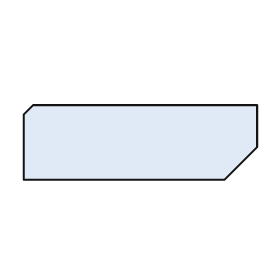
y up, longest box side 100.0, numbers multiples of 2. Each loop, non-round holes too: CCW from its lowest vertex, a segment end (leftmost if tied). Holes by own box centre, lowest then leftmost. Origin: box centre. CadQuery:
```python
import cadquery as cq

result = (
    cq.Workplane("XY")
    .moveTo(-50.0, -16.0)
    .lineTo(36.0, -16.0)
    .lineTo(50.0, -2.0)
    .lineTo(50.0, 16.0)
    .lineTo(-46.0, 16.0)
    .lineTo(-50.0, 12.0)
    .close()
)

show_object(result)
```